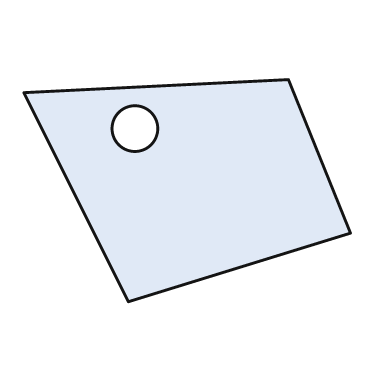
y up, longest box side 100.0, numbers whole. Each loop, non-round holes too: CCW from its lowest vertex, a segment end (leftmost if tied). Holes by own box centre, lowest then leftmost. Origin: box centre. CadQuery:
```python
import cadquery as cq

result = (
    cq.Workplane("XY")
    .moveTo(-18.0, -34.0)
    .lineTo(50.0, -13.0)
    .lineTo(31.0, 34.0)
    .lineTo(-50.0, 30.0)
    .close()
    .moveTo(-16.0, 19.0)
    .circle(7.0)
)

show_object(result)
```